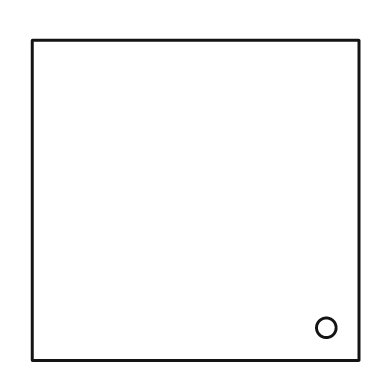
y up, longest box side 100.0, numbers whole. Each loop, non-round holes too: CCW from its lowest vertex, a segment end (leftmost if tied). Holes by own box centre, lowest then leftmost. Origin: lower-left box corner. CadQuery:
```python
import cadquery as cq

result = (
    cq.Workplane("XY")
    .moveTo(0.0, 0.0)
    .lineTo(100.0, 0.0)
    .lineTo(100.0, 98.0)
    .lineTo(0.0, 98.0)
    .close()
    .moveTo(90.0, 10.0)
    .circle(3.0)
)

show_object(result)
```